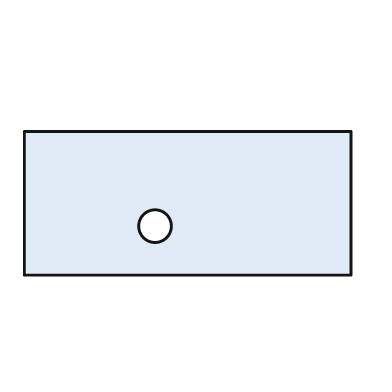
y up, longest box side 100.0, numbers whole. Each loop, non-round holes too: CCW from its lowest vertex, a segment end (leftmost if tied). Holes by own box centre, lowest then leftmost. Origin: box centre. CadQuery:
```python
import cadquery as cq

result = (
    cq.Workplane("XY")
    .moveTo(-50.0, -22.0)
    .lineTo(50.0, -22.0)
    .lineTo(50.0, 22.0)
    .lineTo(-50.0, 22.0)
    .close()
    .moveTo(-10.0, -7.0)
    .circle(5.0)
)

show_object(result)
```